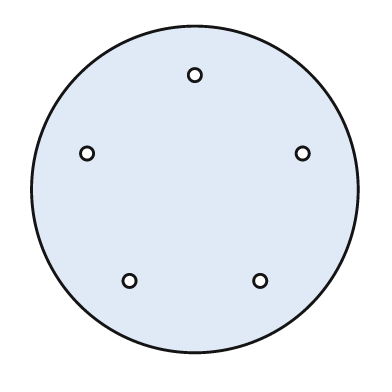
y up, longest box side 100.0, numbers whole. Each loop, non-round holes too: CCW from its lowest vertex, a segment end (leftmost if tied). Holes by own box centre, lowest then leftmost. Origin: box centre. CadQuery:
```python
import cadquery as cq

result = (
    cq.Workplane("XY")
    .moveTo(0.0, 0.0)
    .circle(50.0)
    .moveTo(-20.0, -28.0)
    .circle(2.0)
    .moveTo(20.0, -28.0)
    .circle(2.0)
    .moveTo(-33.0, 11.0)
    .circle(2.0)
    .moveTo(33.0, 11.0)
    .circle(2.0)
    .moveTo(0.0, 35.0)
    .circle(2.0)
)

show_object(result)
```